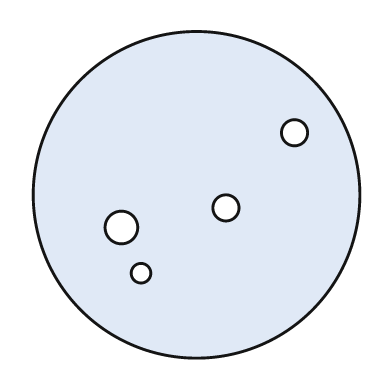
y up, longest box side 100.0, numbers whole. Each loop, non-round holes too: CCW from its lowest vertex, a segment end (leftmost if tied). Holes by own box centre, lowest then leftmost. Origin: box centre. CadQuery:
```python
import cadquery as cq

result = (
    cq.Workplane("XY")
    .moveTo(0.0, 0.0)
    .circle(50.0)
    .moveTo(-17.0, -24.0)
    .circle(3.0)
    .moveTo(-23.0, -10.0)
    .circle(5.0)
    .moveTo(9.0, -4.0)
    .circle(4.0)
    .moveTo(30.0, 19.0)
    .circle(4.0)
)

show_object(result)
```